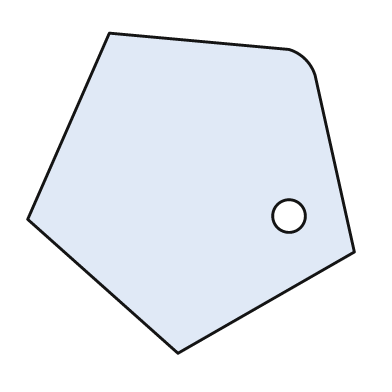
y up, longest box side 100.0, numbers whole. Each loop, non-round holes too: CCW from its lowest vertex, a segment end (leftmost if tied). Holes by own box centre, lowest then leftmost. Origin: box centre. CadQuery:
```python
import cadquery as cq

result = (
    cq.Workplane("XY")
    .moveTo(-4.0, -49.0)
    .lineTo(50.0, -18.0)
    .lineTo(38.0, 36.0)
    .threePointArc((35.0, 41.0), (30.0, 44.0))
    .lineTo(-25.0, 49.0)
    .lineTo(-50.0, -8.0)
    .close()
    .moveTo(30.0, -7.0)
    .circle(5.0)
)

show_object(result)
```